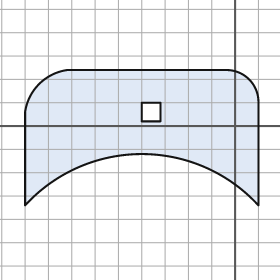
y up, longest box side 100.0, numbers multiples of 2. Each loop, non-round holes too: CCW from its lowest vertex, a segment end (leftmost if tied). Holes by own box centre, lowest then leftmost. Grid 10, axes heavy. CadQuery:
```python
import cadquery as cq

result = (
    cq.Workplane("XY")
    .moveTo(-90.0, -34.0)
    .threePointArc((-40.0, -12.0), (10.0, -34.0))
    .lineTo(10.0, 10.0)
    .threePointArc((6.0, 20.0), (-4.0, 24.0))
    .lineTo(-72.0, 24.0)
    .threePointArc((-84.0, 18.0), (-90.0, 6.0))
    .close()
    .moveTo(-40.0, 2.0)
    .lineTo(-32.0, 2.0)
    .lineTo(-32.0, 10.0)
    .lineTo(-40.0, 10.0)
    .close()
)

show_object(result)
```